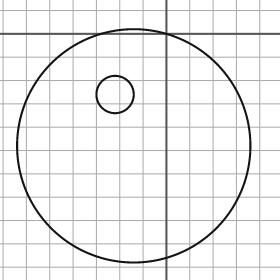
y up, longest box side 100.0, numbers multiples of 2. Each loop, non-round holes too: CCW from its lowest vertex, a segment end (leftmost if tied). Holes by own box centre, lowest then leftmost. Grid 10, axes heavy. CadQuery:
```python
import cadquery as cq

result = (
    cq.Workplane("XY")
    .moveTo(-14.0, -48.0)
    .circle(50.0)
    .moveTo(-22.0, -26.0)
    .circle(8.0)
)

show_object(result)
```